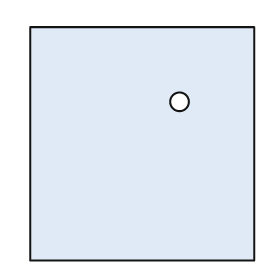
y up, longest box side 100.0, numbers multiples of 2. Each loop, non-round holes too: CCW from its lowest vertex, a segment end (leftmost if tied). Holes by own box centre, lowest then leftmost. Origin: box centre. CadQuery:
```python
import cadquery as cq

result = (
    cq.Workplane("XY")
    .moveTo(-48.0, -50.0)
    .lineTo(48.0, -50.0)
    .lineTo(48.0, 50.0)
    .lineTo(-48.0, 50.0)
    .close()
    .moveTo(16.0, 18.0)
    .circle(4.0)
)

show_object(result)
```